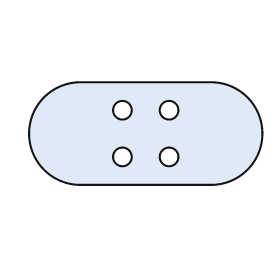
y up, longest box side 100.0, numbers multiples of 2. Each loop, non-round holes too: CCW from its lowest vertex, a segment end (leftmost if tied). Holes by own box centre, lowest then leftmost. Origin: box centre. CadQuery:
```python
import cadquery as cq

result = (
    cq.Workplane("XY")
    .moveTo(-28.0, -22.0)
    .lineTo(28.0, -22.0)
    .threePointArc((50.0, 0.0), (28.0, 22.0))
    .lineTo(-28.0, 22.0)
    .threePointArc((-50.0, 0.0), (-28.0, -22.0))
    .close()
    .moveTo(-10.0, -10.0)
    .circle(4.0)
    .moveTo(10.0, -10.0)
    .circle(4.0)
    .moveTo(-10.0, 10.0)
    .circle(4.0)
    .moveTo(10.0, 10.0)
    .circle(4.0)
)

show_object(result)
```